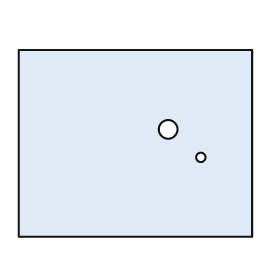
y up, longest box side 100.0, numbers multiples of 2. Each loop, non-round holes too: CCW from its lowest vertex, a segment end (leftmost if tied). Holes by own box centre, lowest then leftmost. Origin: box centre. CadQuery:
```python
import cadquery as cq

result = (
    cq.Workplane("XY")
    .moveTo(-50.0, -40.0)
    .lineTo(50.0, -40.0)
    .lineTo(50.0, 40.0)
    .lineTo(-50.0, 40.0)
    .close()
    .moveTo(28.0, -6.0)
    .circle(2.0)
    .moveTo(14.0, 6.0)
    .circle(4.0)
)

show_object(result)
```